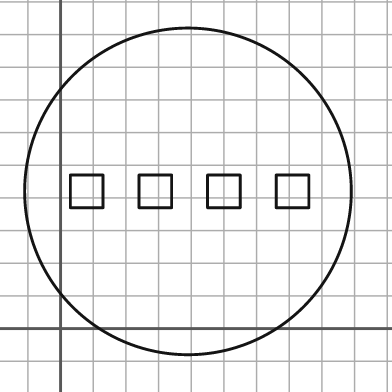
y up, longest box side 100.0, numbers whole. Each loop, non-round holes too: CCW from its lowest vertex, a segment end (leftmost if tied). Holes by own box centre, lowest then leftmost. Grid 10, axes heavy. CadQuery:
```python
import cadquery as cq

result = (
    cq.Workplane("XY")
    .moveTo(39.0, 42.0)
    .circle(50.0)
    .moveTo(3.0, 37.0)
    .lineTo(13.0, 37.0)
    .lineTo(13.0, 47.0)
    .lineTo(3.0, 47.0)
    .close()
    .moveTo(24.0, 37.0)
    .lineTo(34.0, 37.0)
    .lineTo(34.0, 47.0)
    .lineTo(24.0, 47.0)
    .close()
    .moveTo(45.0, 37.0)
    .lineTo(55.0, 37.0)
    .lineTo(55.0, 47.0)
    .lineTo(45.0, 47.0)
    .close()
    .moveTo(66.0, 37.0)
    .lineTo(76.0, 37.0)
    .lineTo(76.0, 47.0)
    .lineTo(66.0, 47.0)
    .close()
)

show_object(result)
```